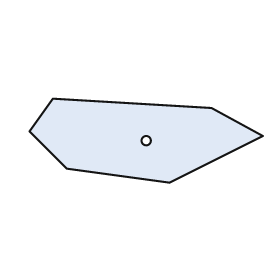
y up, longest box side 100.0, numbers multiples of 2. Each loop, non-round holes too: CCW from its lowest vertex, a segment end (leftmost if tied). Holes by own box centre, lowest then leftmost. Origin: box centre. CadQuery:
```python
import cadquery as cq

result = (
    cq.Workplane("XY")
    .moveTo(10.0, -18.0)
    .lineTo(50.0, 2.0)
    .lineTo(28.0, 14.0)
    .lineTo(-40.0, 18.0)
    .lineTo(-50.0, 4.0)
    .lineTo(-34.0, -12.0)
    .close()
    .moveTo(0.0, 0.0)
    .circle(2.0)
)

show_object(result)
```